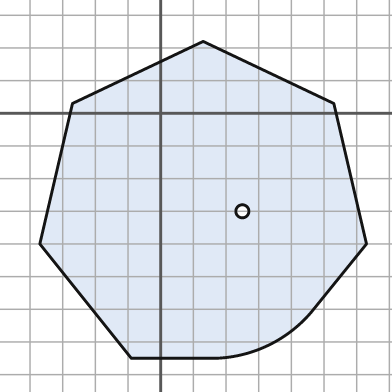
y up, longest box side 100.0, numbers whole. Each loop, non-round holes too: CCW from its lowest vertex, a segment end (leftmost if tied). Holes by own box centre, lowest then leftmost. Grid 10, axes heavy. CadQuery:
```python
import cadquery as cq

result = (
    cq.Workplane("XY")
    .moveTo(-9.0, -75.0)
    .lineTo(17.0, -75.0)
    .threePointArc((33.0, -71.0), (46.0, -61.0))
    .lineTo(63.0, -40.0)
    .lineTo(53.0, 3.0)
    .lineTo(13.0, 22.0)
    .lineTo(-27.0, 3.0)
    .lineTo(-37.0, -40.0)
    .close()
    .moveTo(25.0, -30.0)
    .circle(2.0)
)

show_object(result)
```